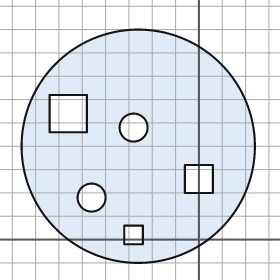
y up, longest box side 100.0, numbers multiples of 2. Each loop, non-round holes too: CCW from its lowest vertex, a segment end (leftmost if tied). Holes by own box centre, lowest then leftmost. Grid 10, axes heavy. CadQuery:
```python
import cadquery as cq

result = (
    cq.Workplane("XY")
    .moveTo(-26.0, 40.0)
    .circle(50.0)
    .moveTo(-32.0, -2.0)
    .lineTo(-24.0, -2.0)
    .lineTo(-24.0, 6.0)
    .lineTo(-32.0, 6.0)
    .close()
    .moveTo(-46.0, 18.0)
    .circle(6.0)
    .moveTo(-6.0, 20.0)
    .lineTo(6.0, 20.0)
    .lineTo(6.0, 32.0)
    .lineTo(-6.0, 32.0)
    .close()
    .moveTo(-28.0, 48.0)
    .circle(6.0)
    .moveTo(-64.0, 46.0)
    .lineTo(-48.0, 46.0)
    .lineTo(-48.0, 62.0)
    .lineTo(-64.0, 62.0)
    .close()
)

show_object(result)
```